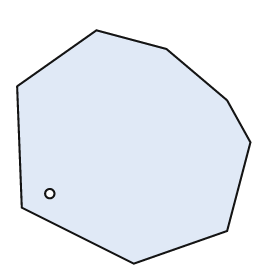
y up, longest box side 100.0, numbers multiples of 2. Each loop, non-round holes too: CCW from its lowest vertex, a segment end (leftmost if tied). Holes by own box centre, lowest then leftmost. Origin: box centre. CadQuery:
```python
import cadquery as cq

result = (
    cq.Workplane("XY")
    .moveTo(0.0, -50.0)
    .lineTo(40.0, -36.0)
    .lineTo(50.0, 2.0)
    .lineTo(40.0, 20.0)
    .lineTo(14.0, 42.0)
    .lineTo(-16.0, 50.0)
    .lineTo(-50.0, 26.0)
    .lineTo(-48.0, -26.0)
    .close()
    .moveTo(-36.0, -20.0)
    .circle(2.0)
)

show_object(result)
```